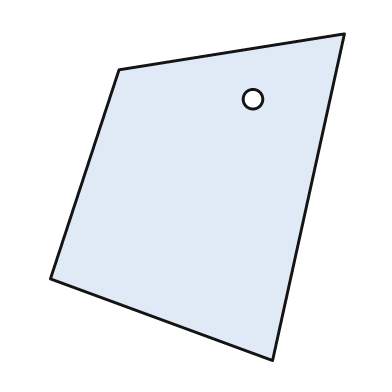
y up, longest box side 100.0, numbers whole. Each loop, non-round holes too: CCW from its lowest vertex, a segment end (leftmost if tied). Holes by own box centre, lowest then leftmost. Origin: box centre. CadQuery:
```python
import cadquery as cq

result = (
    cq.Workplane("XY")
    .moveTo(23.0, -50.0)
    .lineTo(45.0, 50.0)
    .lineTo(-24.0, 39.0)
    .lineTo(-45.0, -25.0)
    .close()
    .moveTo(17.0, 30.0)
    .circle(3.0)
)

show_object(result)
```